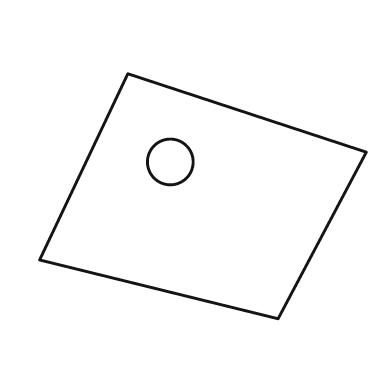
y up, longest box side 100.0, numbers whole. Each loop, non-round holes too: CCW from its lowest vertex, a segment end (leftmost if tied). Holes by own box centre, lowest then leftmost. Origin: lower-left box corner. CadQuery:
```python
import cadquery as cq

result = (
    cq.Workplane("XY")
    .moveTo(73.0, 0.0)
    .lineTo(100.0, 51.0)
    .lineTo(27.0, 75.0)
    .lineTo(0.0, 18.0)
    .close()
    .moveTo(40.0, 48.0)
    .circle(7.0)
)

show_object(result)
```